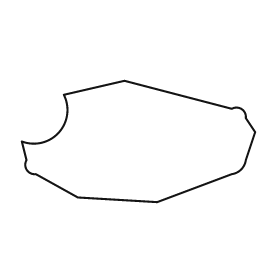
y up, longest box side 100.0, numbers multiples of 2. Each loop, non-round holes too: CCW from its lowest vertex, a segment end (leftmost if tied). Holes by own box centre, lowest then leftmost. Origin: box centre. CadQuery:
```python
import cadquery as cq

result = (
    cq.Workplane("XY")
    .moveTo(8.0, -26.0)
    .lineTo(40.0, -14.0)
    .threePointArc((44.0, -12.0), (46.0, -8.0))
    .lineTo(50.0, 4.0)
    .lineTo(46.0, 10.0)
    .threePointArc((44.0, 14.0), (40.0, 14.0))
    .lineTo(-6.0, 26.0)
    .lineTo(-32.0, 20.0)
    .threePointArc((-34.0, 4.0), (-50.0, 0.0))
    .lineTo(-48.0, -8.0)
    .threePointArc((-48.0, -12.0), (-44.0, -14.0))
    .lineTo(-26.0, -24.0)
    .close()
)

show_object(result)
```